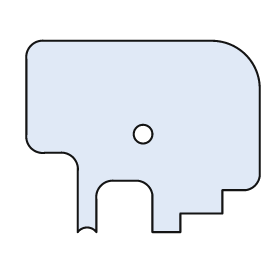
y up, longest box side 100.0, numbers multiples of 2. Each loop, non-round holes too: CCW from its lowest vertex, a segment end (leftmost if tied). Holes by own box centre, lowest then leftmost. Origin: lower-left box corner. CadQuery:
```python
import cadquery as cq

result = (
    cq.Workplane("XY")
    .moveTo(22.0, 0.0)
    .threePointArc((26.0, 2.0), (30.0, 0.0))
    .lineTo(30.0, 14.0)
    .threePointArc((32.0, 20.0), (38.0, 22.0))
    .lineTo(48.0, 22.0)
    .threePointArc((52.0, 20.0), (54.0, 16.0))
    .lineTo(54.0, 0.0)
    .lineTo(66.0, 0.0)
    .lineTo(66.0, 8.0)
    .lineTo(84.0, 8.0)
    .lineTo(84.0, 18.0)
    .lineTo(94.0, 18.0)
    .threePointArc((98.0, 20.0), (100.0, 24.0))
    .lineTo(100.0, 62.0)
    .threePointArc((94.0, 76.0), (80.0, 82.0))
    .lineTo(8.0, 82.0)
    .threePointArc((2.0, 80.0), (0.0, 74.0))
    .lineTo(0.0, 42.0)
    .threePointArc((2.0, 36.0), (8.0, 34.0))
    .lineTo(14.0, 34.0)
    .threePointArc((20.0, 32.0), (22.0, 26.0))
    .close()
    .moveTo(50.0, 42.0)
    .circle(4.0)
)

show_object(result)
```